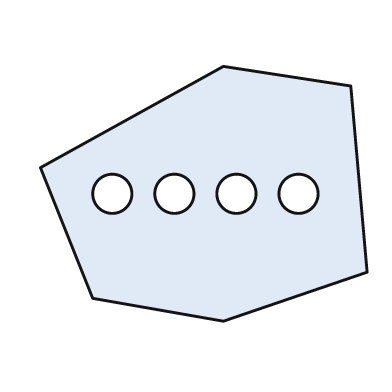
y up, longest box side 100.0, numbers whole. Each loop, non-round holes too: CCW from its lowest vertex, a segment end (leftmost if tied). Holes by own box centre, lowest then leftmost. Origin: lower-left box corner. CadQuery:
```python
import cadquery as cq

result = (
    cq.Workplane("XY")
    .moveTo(56.0, 0.0)
    .lineTo(100.0, 15.0)
    .lineTo(95.0, 72.0)
    .lineTo(56.0, 78.0)
    .lineTo(0.0, 47.0)
    .lineTo(16.0, 7.0)
    .close()
    .moveTo(22.0, 39.0)
    .circle(6.0)
    .moveTo(41.0, 39.0)
    .circle(6.0)
    .moveTo(60.0, 39.0)
    .circle(6.0)
    .moveTo(79.0, 39.0)
    .circle(6.0)
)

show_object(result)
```